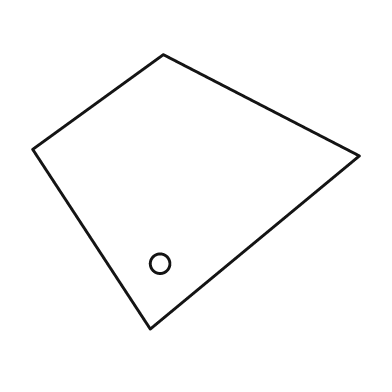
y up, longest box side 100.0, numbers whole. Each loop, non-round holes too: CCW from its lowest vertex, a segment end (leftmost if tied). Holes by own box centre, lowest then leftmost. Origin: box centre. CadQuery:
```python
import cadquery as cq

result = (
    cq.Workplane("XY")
    .moveTo(-14.0, -42.0)
    .lineTo(50.0, 11.0)
    .lineTo(-10.0, 42.0)
    .lineTo(-50.0, 13.0)
    .close()
    .moveTo(-11.0, -22.0)
    .circle(3.0)
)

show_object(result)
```